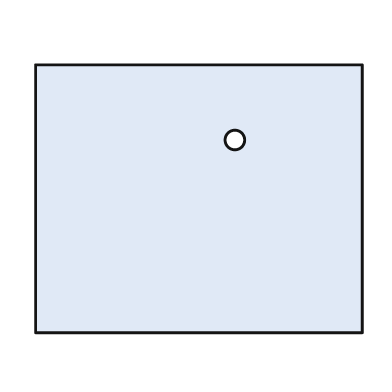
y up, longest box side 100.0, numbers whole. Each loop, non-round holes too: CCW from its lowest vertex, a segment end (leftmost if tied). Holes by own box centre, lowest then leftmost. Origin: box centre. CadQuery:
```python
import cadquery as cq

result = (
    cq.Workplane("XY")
    .moveTo(-50.0, -41.0)
    .lineTo(50.0, -41.0)
    .lineTo(50.0, 41.0)
    .lineTo(-50.0, 41.0)
    .close()
    .moveTo(11.0, 18.0)
    .circle(3.0)
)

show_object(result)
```